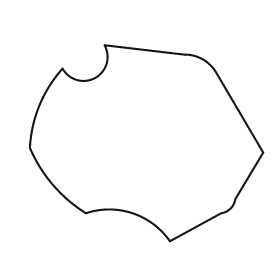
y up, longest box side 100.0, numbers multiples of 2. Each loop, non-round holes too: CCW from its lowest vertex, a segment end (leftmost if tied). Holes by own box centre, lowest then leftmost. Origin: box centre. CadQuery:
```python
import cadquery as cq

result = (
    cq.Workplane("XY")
    .moveTo(10.0, -42.0)
    .lineTo(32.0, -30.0)
    .threePointArc((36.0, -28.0), (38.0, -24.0))
    .lineTo(50.0, -4.0)
    .lineTo(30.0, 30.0)
    .threePointArc((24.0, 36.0), (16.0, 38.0))
    .lineTo(-18.0, 42.0)
    .threePointArc((-22.0, 28.0), (-36.0, 32.0))
    .threePointArc((-46.0, 16.0), (-50.0, -2.0))
    .threePointArc((-40.0, -18.0), (-26.0, -30.0))
    .threePointArc((-6.0, -30.0), (10.0, -42.0))
    .close()
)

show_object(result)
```